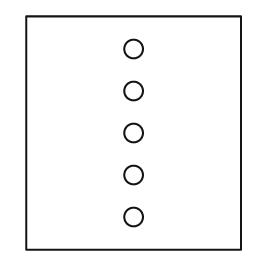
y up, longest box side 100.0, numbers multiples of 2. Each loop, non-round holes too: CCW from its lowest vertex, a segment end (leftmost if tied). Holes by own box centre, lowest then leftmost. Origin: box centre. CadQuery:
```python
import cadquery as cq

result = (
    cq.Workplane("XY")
    .moveTo(-46.0, -50.0)
    .lineTo(46.0, -50.0)
    .lineTo(46.0, 50.0)
    .lineTo(-46.0, 50.0)
    .close()
    .moveTo(0.0, -36.0)
    .circle(4.0)
    .moveTo(0.0, -18.0)
    .circle(4.0)
    .moveTo(0.0, 0.0)
    .circle(4.0)
    .moveTo(0.0, 18.0)
    .circle(4.0)
    .moveTo(0.0, 36.0)
    .circle(4.0)
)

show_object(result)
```